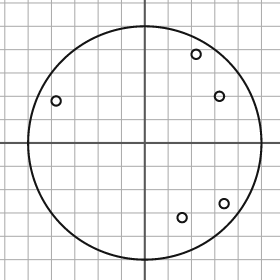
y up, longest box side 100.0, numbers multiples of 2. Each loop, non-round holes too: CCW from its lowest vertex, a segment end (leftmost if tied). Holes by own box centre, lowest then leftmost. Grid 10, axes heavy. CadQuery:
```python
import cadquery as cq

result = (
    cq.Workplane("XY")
    .moveTo(0.0, 0.0)
    .circle(50.0)
    .moveTo(16.0, -32.0)
    .circle(2.0)
    .moveTo(34.0, -26.0)
    .circle(2.0)
    .moveTo(-38.0, 18.0)
    .circle(2.0)
    .moveTo(32.0, 20.0)
    .circle(2.0)
    .moveTo(22.0, 38.0)
    .circle(2.0)
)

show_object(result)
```